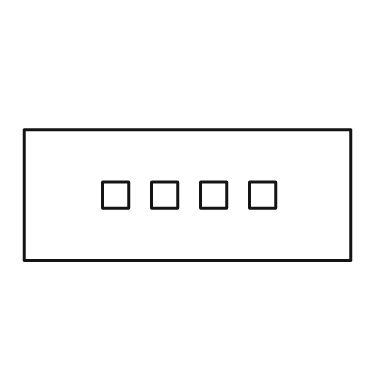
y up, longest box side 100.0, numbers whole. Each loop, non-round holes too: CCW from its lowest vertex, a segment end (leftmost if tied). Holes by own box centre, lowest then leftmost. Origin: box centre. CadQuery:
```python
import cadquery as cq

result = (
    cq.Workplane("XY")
    .moveTo(-50.0, -20.0)
    .lineTo(50.0, -20.0)
    .lineTo(50.0, 20.0)
    .lineTo(-50.0, 20.0)
    .close()
    .moveTo(-26.0, -4.0)
    .lineTo(-18.0, -4.0)
    .lineTo(-18.0, 4.0)
    .lineTo(-26.0, 4.0)
    .close()
    .moveTo(-11.0, -4.0)
    .lineTo(-3.0, -4.0)
    .lineTo(-3.0, 4.0)
    .lineTo(-11.0, 4.0)
    .close()
    .moveTo(4.0, -4.0)
    .lineTo(12.0, -4.0)
    .lineTo(12.0, 4.0)
    .lineTo(4.0, 4.0)
    .close()
    .moveTo(19.0, -4.0)
    .lineTo(27.0, -4.0)
    .lineTo(27.0, 4.0)
    .lineTo(19.0, 4.0)
    .close()
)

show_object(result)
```